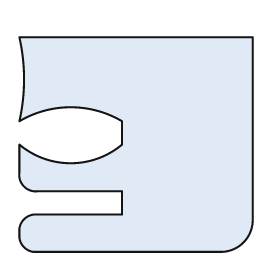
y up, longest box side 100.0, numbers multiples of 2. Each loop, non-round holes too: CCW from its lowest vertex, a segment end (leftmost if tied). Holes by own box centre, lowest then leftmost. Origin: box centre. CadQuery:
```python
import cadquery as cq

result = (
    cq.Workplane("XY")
    .moveTo(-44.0, -46.0)
    .lineTo(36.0, -46.0)
    .threePointArc((46.0, -42.0), (50.0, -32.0))
    .lineTo(50.0, 46.0)
    .lineTo(-50.0, 46.0)
    .threePointArc((-48.0, 28.0), (-50.0, 10.0))
    .threePointArc((-28.0, 16.0), (-6.0, 10.0))
    .lineTo(-6.0, 0.0)
    .threePointArc((-28.0, -8.0), (-50.0, 0.0))
    .lineTo(-50.0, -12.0)
    .threePointArc((-48.0, -18.0), (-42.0, -20.0))
    .lineTo(-6.0, -20.0)
    .lineTo(-6.0, -30.0)
    .lineTo(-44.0, -30.0)
    .threePointArc((-48.0, -32.0), (-50.0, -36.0))
    .lineTo(-50.0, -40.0)
    .threePointArc((-48.0, -44.0), (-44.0, -46.0))
    .close()
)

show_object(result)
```